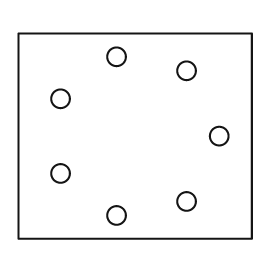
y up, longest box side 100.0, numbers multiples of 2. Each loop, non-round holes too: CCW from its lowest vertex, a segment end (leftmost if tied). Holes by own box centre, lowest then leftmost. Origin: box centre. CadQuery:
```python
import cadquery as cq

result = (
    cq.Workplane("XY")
    .moveTo(-50.0, -44.0)
    .lineTo(50.0, -44.0)
    .lineTo(50.0, 44.0)
    .lineTo(-50.0, 44.0)
    .close()
    .moveTo(-8.0, -34.0)
    .circle(4.0)
    .moveTo(22.0, -28.0)
    .circle(4.0)
    .moveTo(-32.0, -16.0)
    .circle(4.0)
    .moveTo(36.0, 0.0)
    .circle(4.0)
    .moveTo(-32.0, 16.0)
    .circle(4.0)
    .moveTo(22.0, 28.0)
    .circle(4.0)
    .moveTo(-8.0, 34.0)
    .circle(4.0)
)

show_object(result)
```